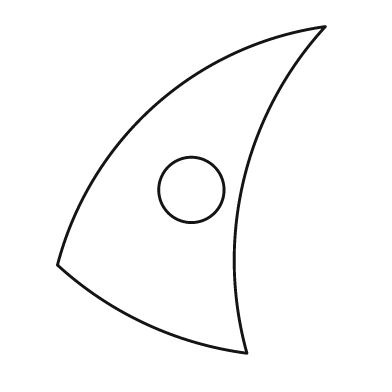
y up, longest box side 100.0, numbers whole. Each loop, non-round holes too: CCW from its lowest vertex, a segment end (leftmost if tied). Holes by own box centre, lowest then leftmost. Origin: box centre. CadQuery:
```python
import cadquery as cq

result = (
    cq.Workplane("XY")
    .moveTo(17.0, -50.0)
    .threePointArc((16.0, 3.0), (41.0, 50.0))
    .threePointArc((-11.0, 26.0), (-41.0, -23.0))
    .threePointArc((-14.0, -41.0), (17.0, -50.0))
    .close()
    .moveTo(0.0, 0.0)
    .circle(10.0)
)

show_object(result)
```